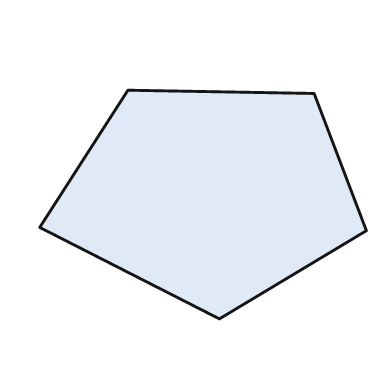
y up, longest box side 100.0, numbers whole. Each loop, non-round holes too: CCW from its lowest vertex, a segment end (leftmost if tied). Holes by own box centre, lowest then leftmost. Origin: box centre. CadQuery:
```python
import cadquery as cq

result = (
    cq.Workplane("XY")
    .moveTo(5.0, -35.0)
    .lineTo(50.0, -8.0)
    .lineTo(34.0, 34.0)
    .lineTo(-23.0, 35.0)
    .lineTo(-50.0, -7.0)
    .close()
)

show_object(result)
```